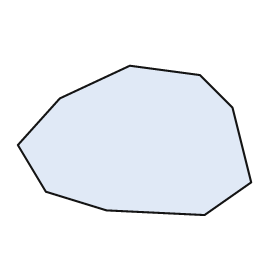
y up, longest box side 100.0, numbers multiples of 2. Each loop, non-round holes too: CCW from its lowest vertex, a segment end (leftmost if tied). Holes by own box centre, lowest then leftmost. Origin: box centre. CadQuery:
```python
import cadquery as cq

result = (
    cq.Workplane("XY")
    .moveTo(30.0, -32.0)
    .lineTo(50.0, -18.0)
    .lineTo(42.0, 14.0)
    .lineTo(28.0, 28.0)
    .lineTo(-2.0, 32.0)
    .lineTo(-32.0, 18.0)
    .lineTo(-50.0, -2.0)
    .lineTo(-38.0, -22.0)
    .lineTo(-12.0, -30.0)
    .close()
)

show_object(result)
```